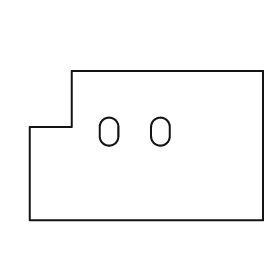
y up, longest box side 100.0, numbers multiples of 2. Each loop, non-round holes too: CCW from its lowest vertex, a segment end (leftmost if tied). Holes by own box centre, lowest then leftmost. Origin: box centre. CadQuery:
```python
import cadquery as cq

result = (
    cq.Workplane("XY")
    .moveTo(-50.0, -32.0)
    .lineTo(50.0, -32.0)
    .lineTo(50.0, 32.0)
    .lineTo(-32.0, 32.0)
    .lineTo(-32.0, 8.0)
    .lineTo(-50.0, 8.0)
    .close()
    .moveTo(-20.0, 4.0)
    .threePointArc((-16.0, 0.0), (-12.0, 4.0))
    .lineTo(-12.0, 8.0)
    .threePointArc((-16.0, 12.0), (-20.0, 8.0))
    .close()
    .moveTo(2.0, 4.0)
    .threePointArc((6.0, 0.0), (10.0, 4.0))
    .lineTo(10.0, 8.0)
    .threePointArc((6.0, 12.0), (2.0, 8.0))
    .close()
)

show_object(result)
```